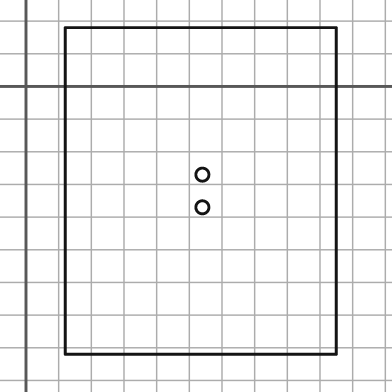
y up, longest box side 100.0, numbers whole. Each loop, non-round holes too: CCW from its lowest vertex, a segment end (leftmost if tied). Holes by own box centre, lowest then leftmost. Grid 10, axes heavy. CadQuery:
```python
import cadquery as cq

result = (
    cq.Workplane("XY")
    .moveTo(12.0, -82.0)
    .lineTo(95.0, -82.0)
    .lineTo(95.0, 18.0)
    .lineTo(12.0, 18.0)
    .close()
    .moveTo(54.0, -37.0)
    .circle(2.0)
    .moveTo(54.0, -27.0)
    .circle(2.0)
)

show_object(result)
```